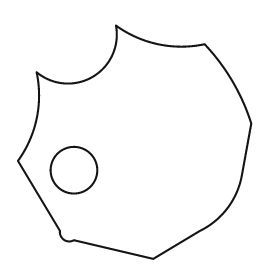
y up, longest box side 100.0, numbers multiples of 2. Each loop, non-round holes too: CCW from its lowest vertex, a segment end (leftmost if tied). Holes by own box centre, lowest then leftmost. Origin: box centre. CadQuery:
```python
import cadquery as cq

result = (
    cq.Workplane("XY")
    .moveTo(8.0, -50.0)
    .lineTo(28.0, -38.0)
    .threePointArc((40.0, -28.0), (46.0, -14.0))
    .lineTo(50.0, 8.0)
    .threePointArc((42.0, 26.0), (30.0, 42.0))
    .threePointArc((10.0, 42.0), (-8.0, 50.0))
    .threePointArc((-18.0, 28.0), (-42.0, 30.0))
    .threePointArc((-42.0, 10.0), (-50.0, -8.0))
    .lineTo(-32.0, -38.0)
    .threePointArc((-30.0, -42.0), (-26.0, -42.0))
    .close()
    .moveTo(-26.0, -12.0)
    .circle(10.0)
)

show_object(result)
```